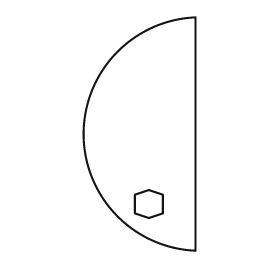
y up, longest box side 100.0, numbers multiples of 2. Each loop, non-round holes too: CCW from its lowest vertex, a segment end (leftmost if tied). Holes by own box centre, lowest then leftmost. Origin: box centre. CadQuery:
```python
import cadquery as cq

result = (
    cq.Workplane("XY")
    .moveTo(24.0, -50.0)
    .lineTo(24.0, 50.0)
    .threePointArc((-24.0, 0.0), (24.0, -50.0))
    .close()
    .moveTo(4.0, -36.0)
    .lineTo(10.0, -34.0)
    .lineTo(10.0, -26.0)
    .lineTo(4.0, -24.0)
    .lineTo(-2.0, -26.0)
    .lineTo(-2.0, -34.0)
    .close()
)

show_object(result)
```